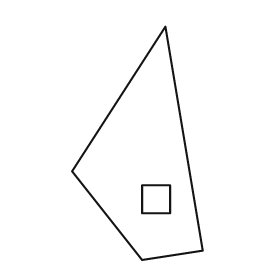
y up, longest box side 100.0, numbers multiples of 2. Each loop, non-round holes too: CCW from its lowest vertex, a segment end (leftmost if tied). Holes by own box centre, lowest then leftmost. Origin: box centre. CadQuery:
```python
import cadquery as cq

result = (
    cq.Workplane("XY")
    .moveTo(2.0, -50.0)
    .lineTo(28.0, -46.0)
    .lineTo(12.0, 50.0)
    .lineTo(-28.0, -12.0)
    .close()
    .moveTo(2.0, -30.0)
    .lineTo(14.0, -30.0)
    .lineTo(14.0, -18.0)
    .lineTo(2.0, -18.0)
    .close()
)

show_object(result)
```